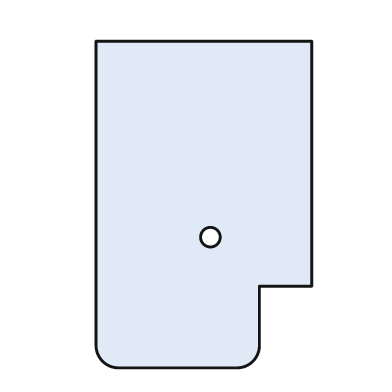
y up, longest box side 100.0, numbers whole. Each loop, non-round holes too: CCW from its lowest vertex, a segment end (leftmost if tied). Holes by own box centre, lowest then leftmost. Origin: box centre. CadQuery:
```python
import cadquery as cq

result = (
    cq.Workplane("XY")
    .moveTo(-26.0, -50.0)
    .lineTo(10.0, -50.0)
    .threePointArc((15.0, -48.0), (17.0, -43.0))
    .lineTo(17.0, -25.0)
    .lineTo(33.0, -25.0)
    .lineTo(33.0, 50.0)
    .lineTo(-33.0, 50.0)
    .lineTo(-33.0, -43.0)
    .threePointArc((-31.0, -48.0), (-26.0, -50.0))
    .close()
    .moveTo(2.0, -10.0)
    .circle(3.0)
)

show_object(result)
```